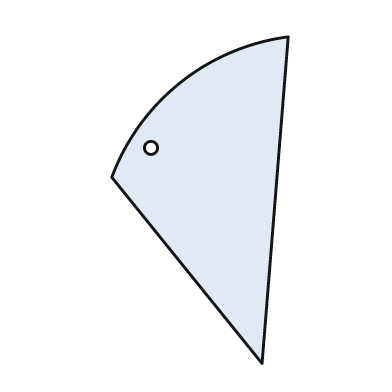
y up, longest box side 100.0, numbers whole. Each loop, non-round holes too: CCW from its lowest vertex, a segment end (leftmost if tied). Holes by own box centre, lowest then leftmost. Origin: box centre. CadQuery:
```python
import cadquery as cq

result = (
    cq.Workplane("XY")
    .moveTo(19.0, -50.0)
    .lineTo(27.0, 50.0)
    .threePointArc((-6.0, 36.0), (-27.0, 7.0))
    .close()
    .moveTo(-15.0, 16.0)
    .circle(2.0)
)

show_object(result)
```